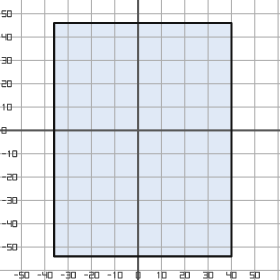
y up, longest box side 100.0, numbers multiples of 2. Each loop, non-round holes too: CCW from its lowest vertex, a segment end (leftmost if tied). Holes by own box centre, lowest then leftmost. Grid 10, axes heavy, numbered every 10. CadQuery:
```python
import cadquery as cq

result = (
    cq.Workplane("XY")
    .moveTo(-36.0, -54.0)
    .lineTo(40.0, -54.0)
    .lineTo(40.0, 46.0)
    .lineTo(-36.0, 46.0)
    .close()
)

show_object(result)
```